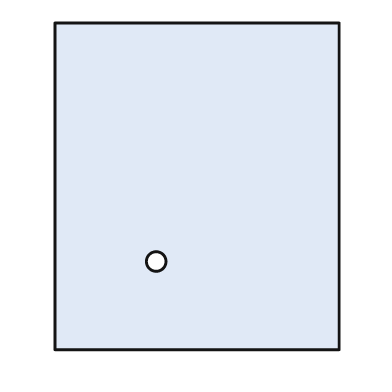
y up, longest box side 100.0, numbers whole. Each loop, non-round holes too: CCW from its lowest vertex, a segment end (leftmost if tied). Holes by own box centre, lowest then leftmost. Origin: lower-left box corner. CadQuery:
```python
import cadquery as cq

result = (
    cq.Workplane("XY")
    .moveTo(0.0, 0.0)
    .lineTo(87.0, 0.0)
    .lineTo(87.0, 100.0)
    .lineTo(0.0, 100.0)
    .close()
    .moveTo(31.0, 27.0)
    .circle(3.0)
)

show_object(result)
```